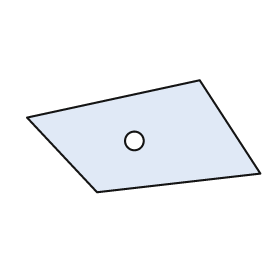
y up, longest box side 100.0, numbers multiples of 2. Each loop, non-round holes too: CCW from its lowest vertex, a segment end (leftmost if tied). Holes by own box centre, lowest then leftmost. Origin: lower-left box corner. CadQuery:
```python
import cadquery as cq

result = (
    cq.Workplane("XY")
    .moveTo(30.0, 0.0)
    .lineTo(100.0, 8.0)
    .lineTo(74.0, 48.0)
    .lineTo(0.0, 32.0)
    .close()
    .moveTo(46.0, 22.0)
    .circle(4.0)
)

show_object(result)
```